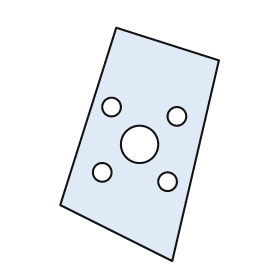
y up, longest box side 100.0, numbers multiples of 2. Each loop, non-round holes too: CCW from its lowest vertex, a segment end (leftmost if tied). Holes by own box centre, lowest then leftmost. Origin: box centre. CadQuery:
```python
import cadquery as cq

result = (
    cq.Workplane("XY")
    .moveTo(14.0, -50.0)
    .lineTo(34.0, 36.0)
    .lineTo(-10.0, 50.0)
    .lineTo(-34.0, -26.0)
    .close()
    .moveTo(12.0, -16.0)
    .circle(4.0)
    .moveTo(-16.0, -12.0)
    .circle(4.0)
    .moveTo(0.0, 0.0)
    .circle(8.0)
    .moveTo(16.0, 12.0)
    .circle(4.0)
    .moveTo(-12.0, 16.0)
    .circle(4.0)
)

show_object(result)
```